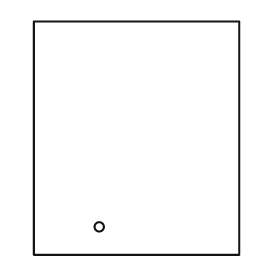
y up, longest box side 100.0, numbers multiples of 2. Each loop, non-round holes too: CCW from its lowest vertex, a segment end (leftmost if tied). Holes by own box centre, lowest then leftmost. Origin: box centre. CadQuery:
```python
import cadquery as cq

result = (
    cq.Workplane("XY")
    .moveTo(-44.0, -50.0)
    .lineTo(44.0, -50.0)
    .lineTo(44.0, 50.0)
    .lineTo(-44.0, 50.0)
    .close()
    .moveTo(-16.0, -38.0)
    .circle(2.0)
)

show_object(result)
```